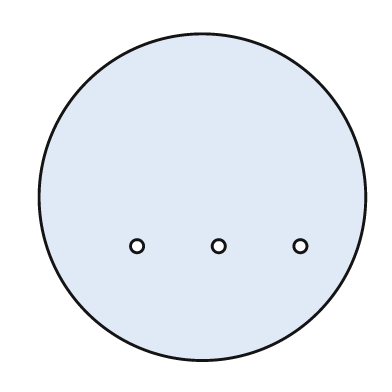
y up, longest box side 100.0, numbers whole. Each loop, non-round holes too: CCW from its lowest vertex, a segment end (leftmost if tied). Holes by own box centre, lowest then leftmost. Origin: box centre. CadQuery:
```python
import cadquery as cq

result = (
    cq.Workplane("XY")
    .moveTo(0.0, 0.0)
    .circle(50.0)
    .moveTo(-20.0, -15.0)
    .circle(2.0)
    .moveTo(5.0, -15.0)
    .circle(2.0)
    .moveTo(30.0, -15.0)
    .circle(2.0)
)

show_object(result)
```